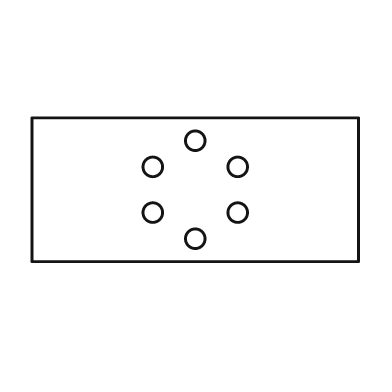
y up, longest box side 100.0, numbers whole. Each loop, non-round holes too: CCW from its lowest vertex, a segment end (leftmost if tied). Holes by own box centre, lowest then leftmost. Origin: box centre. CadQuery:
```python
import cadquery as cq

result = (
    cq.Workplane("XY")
    .moveTo(-50.0, -22.0)
    .lineTo(50.0, -22.0)
    .lineTo(50.0, 22.0)
    .lineTo(-50.0, 22.0)
    .close()
    .moveTo(0.0, -15.0)
    .circle(3.0)
    .moveTo(-13.0, -7.0)
    .circle(3.0)
    .moveTo(13.0, -7.0)
    .circle(3.0)
    .moveTo(-13.0, 7.0)
    .circle(3.0)
    .moveTo(13.0, 7.0)
    .circle(3.0)
    .moveTo(0.0, 15.0)
    .circle(3.0)
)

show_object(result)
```